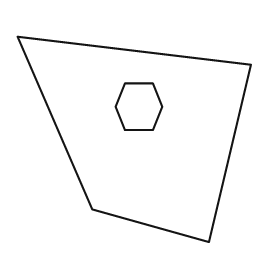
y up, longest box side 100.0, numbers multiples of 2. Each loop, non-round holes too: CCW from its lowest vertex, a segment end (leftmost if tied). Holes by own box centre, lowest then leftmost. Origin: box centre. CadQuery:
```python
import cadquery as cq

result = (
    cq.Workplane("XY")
    .moveTo(32.0, -44.0)
    .lineTo(50.0, 32.0)
    .lineTo(-50.0, 44.0)
    .lineTo(-18.0, -30.0)
    .close()
    .moveTo(-4.0, 4.0)
    .lineTo(8.0, 4.0)
    .lineTo(12.0, 14.0)
    .lineTo(8.0, 24.0)
    .lineTo(-4.0, 24.0)
    .lineTo(-8.0, 14.0)
    .close()
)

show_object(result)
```